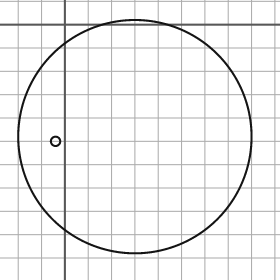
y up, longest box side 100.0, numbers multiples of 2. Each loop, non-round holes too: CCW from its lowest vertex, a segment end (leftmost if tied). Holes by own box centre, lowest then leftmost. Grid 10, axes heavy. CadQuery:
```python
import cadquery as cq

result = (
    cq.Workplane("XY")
    .moveTo(30.0, -48.0)
    .circle(50.0)
    .moveTo(-4.0, -50.0)
    .circle(2.0)
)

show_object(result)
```